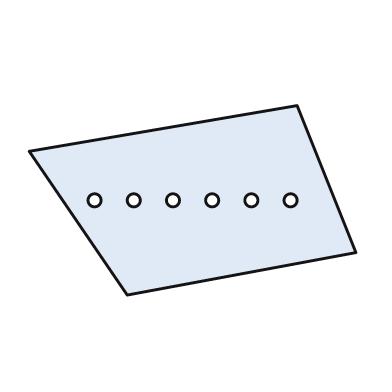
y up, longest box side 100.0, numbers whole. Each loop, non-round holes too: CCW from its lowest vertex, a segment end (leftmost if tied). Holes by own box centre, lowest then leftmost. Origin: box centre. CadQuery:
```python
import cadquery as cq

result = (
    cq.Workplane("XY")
    .moveTo(-20.0, -29.0)
    .lineTo(50.0, -16.0)
    .lineTo(32.0, 29.0)
    .lineTo(-50.0, 15.0)
    .close()
    .moveTo(-30.0, 0.0)
    .circle(2.0)
    .moveTo(-18.0, 0.0)
    .circle(2.0)
    .moveTo(-6.0, 0.0)
    .circle(2.0)
    .moveTo(6.0, 0.0)
    .circle(2.0)
    .moveTo(18.0, 0.0)
    .circle(2.0)
    .moveTo(30.0, 0.0)
    .circle(2.0)
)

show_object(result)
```